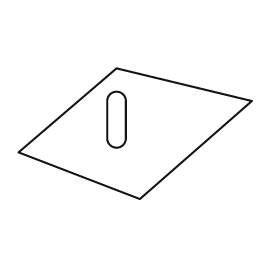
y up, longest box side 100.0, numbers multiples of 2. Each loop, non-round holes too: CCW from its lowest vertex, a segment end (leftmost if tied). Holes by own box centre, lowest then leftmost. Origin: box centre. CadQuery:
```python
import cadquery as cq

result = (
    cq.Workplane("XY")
    .moveTo(2.0, -28.0)
    .lineTo(50.0, 14.0)
    .lineTo(-8.0, 28.0)
    .lineTo(-50.0, -8.0)
    .close()
    .moveTo(-12.0, -2.0)
    .threePointArc((-8.0, -6.0), (-4.0, -2.0))
    .lineTo(-4.0, 14.0)
    .threePointArc((-8.0, 18.0), (-12.0, 14.0))
    .close()
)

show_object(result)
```